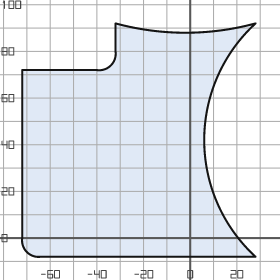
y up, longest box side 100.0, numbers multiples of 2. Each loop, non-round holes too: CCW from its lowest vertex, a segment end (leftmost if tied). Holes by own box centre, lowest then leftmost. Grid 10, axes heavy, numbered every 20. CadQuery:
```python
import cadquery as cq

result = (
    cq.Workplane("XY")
    .moveTo(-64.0, -8.0)
    .lineTo(28.0, -8.0)
    .threePointArc((6.0, 42.0), (28.0, 92.0))
    .threePointArc((-2.0, 88.0), (-32.0, 92.0))
    .lineTo(-32.0, 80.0)
    .threePointArc((-34.0, 74.0), (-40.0, 72.0))
    .lineTo(-72.0, 72.0)
    .lineTo(-72.0, 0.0)
    .threePointArc((-70.0, -6.0), (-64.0, -8.0))
    .close()
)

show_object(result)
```